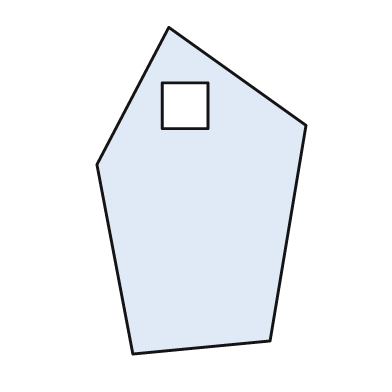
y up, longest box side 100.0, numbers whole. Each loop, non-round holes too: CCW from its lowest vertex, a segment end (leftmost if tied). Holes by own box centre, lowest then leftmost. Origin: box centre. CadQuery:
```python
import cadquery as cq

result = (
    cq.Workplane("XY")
    .moveTo(-21.0, -50.0)
    .lineTo(21.0, -46.0)
    .lineTo(32.0, 20.0)
    .lineTo(-10.0, 50.0)
    .lineTo(-32.0, 8.0)
    .close()
    .moveTo(-12.0, 19.0)
    .lineTo(2.0, 19.0)
    .lineTo(2.0, 33.0)
    .lineTo(-12.0, 33.0)
    .close()
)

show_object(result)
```